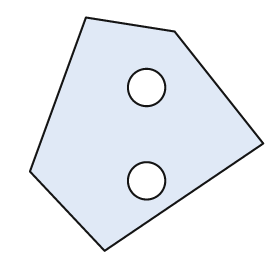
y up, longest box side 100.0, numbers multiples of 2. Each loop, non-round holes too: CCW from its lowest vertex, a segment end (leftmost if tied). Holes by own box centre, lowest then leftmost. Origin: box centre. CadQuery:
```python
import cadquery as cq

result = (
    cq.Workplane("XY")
    .moveTo(-18.0, -50.0)
    .lineTo(50.0, -4.0)
    .lineTo(12.0, 44.0)
    .lineTo(-26.0, 50.0)
    .lineTo(-50.0, -16.0)
    .close()
    .moveTo(0.0, -20.0)
    .circle(8.0)
    .moveTo(0.0, 20.0)
    .circle(8.0)
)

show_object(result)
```